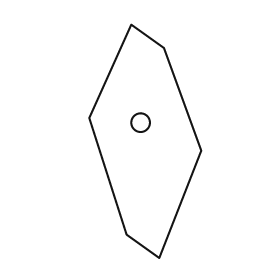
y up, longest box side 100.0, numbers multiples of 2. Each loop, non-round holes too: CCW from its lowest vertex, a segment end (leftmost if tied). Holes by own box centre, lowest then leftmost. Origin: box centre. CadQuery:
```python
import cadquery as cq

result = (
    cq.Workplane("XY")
    .moveTo(6.0, -50.0)
    .lineTo(24.0, -4.0)
    .lineTo(8.0, 40.0)
    .lineTo(-6.0, 50.0)
    .lineTo(-24.0, 10.0)
    .lineTo(-8.0, -40.0)
    .close()
    .moveTo(-2.0, 8.0)
    .circle(4.0)
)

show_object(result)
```